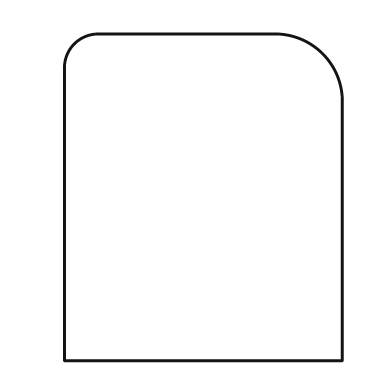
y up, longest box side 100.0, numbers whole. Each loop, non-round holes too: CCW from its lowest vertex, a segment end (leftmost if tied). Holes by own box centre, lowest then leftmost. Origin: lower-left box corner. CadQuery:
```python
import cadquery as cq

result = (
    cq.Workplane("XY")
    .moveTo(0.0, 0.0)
    .lineTo(85.0, 0.0)
    .lineTo(85.0, 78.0)
    .threePointArc((79.0, 94.0), (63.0, 100.0))
    .lineTo(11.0, 100.0)
    .threePointArc((3.0, 97.0), (0.0, 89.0))
    .close()
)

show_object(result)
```